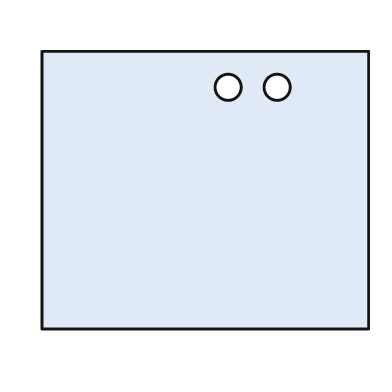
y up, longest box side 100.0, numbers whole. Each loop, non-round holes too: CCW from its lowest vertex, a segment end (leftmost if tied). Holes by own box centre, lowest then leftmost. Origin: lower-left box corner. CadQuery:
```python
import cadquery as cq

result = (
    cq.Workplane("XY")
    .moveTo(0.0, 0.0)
    .lineTo(100.0, 0.0)
    .lineTo(100.0, 85.0)
    .lineTo(0.0, 85.0)
    .close()
    .moveTo(57.0, 74.0)
    .circle(4.0)
    .moveTo(72.0, 74.0)
    .circle(4.0)
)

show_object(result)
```